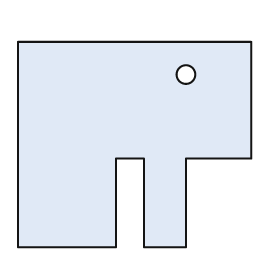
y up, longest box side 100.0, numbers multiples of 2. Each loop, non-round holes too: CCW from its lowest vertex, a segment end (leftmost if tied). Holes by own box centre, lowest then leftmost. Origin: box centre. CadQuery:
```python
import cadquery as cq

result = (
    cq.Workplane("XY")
    .moveTo(-50.0, -44.0)
    .lineTo(-8.0, -44.0)
    .lineTo(-8.0, -6.0)
    .lineTo(4.0, -6.0)
    .lineTo(4.0, -44.0)
    .lineTo(22.0, -44.0)
    .lineTo(22.0, -6.0)
    .lineTo(50.0, -6.0)
    .lineTo(50.0, 44.0)
    .lineTo(-50.0, 44.0)
    .close()
    .moveTo(22.0, 30.0)
    .circle(4.0)
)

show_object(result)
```